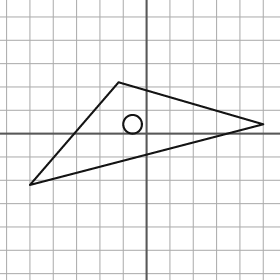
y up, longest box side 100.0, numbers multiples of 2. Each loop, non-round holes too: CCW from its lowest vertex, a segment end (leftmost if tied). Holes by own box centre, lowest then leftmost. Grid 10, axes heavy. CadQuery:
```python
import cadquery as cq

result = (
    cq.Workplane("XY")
    .moveTo(-50.0, -22.0)
    .lineTo(50.0, 4.0)
    .lineTo(-12.0, 22.0)
    .close()
    .moveTo(-6.0, 4.0)
    .circle(4.0)
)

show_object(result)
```